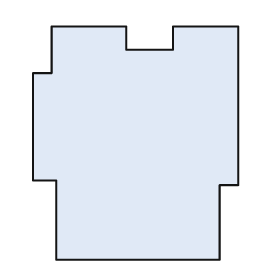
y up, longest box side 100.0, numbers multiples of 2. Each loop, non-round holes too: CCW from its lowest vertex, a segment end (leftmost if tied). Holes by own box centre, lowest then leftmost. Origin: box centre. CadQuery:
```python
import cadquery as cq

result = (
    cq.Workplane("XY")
    .moveTo(-34.0, -50.0)
    .lineTo(36.0, -50.0)
    .lineTo(36.0, -18.0)
    .lineTo(44.0, -18.0)
    .lineTo(44.0, 50.0)
    .lineTo(16.0, 50.0)
    .lineTo(16.0, 40.0)
    .lineTo(-4.0, 40.0)
    .lineTo(-4.0, 50.0)
    .lineTo(-36.0, 50.0)
    .lineTo(-36.0, 30.0)
    .lineTo(-44.0, 30.0)
    .lineTo(-44.0, -16.0)
    .lineTo(-34.0, -16.0)
    .close()
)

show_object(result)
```